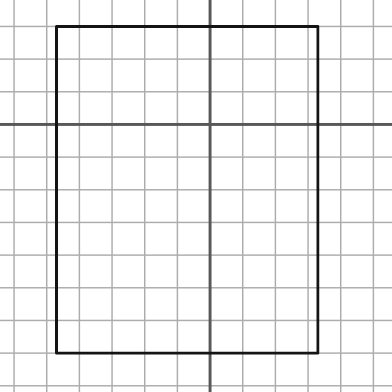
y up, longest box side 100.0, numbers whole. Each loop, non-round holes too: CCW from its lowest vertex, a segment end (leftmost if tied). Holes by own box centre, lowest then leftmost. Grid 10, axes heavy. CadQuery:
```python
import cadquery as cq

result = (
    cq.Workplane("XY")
    .moveTo(-47.0, -70.0)
    .lineTo(33.0, -70.0)
    .lineTo(33.0, 30.0)
    .lineTo(-47.0, 30.0)
    .close()
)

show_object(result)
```